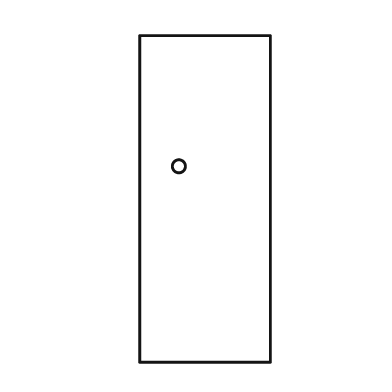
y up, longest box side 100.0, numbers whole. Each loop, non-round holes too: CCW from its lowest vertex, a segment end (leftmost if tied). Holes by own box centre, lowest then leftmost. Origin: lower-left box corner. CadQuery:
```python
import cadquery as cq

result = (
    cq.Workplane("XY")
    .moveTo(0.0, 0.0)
    .lineTo(40.0, 0.0)
    .lineTo(40.0, 100.0)
    .lineTo(0.0, 100.0)
    .close()
    .moveTo(12.0, 60.0)
    .circle(2.0)
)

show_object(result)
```